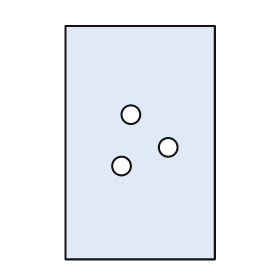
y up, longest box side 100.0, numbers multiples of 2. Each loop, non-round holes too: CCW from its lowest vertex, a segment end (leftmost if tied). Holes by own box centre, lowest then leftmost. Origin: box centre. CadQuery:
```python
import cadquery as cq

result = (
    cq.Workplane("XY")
    .moveTo(-32.0, -50.0)
    .lineTo(32.0, -50.0)
    .lineTo(32.0, 50.0)
    .lineTo(-32.0, 50.0)
    .close()
    .moveTo(-8.0, -10.0)
    .circle(4.0)
    .moveTo(12.0, -2.0)
    .circle(4.0)
    .moveTo(-4.0, 12.0)
    .circle(4.0)
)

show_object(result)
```